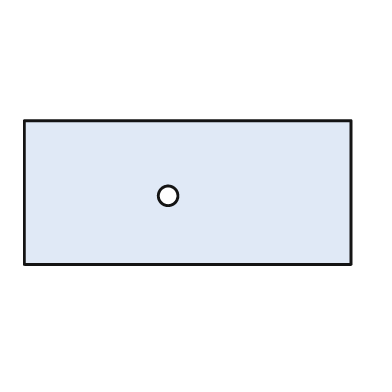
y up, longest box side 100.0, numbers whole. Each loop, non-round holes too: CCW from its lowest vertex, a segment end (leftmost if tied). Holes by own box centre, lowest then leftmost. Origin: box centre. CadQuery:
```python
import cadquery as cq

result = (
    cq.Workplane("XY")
    .moveTo(-50.0, -22.0)
    .lineTo(50.0, -22.0)
    .lineTo(50.0, 22.0)
    .lineTo(-50.0, 22.0)
    .close()
    .moveTo(-6.0, -1.0)
    .circle(3.0)
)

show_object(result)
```